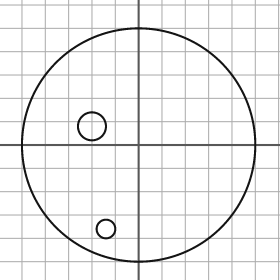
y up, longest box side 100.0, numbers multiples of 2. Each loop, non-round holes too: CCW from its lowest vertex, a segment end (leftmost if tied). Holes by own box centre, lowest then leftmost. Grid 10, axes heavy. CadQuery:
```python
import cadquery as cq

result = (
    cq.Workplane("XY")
    .moveTo(0.0, 0.0)
    .circle(50.0)
    .moveTo(-14.0, -36.0)
    .circle(4.0)
    .moveTo(-20.0, 8.0)
    .circle(6.0)
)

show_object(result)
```